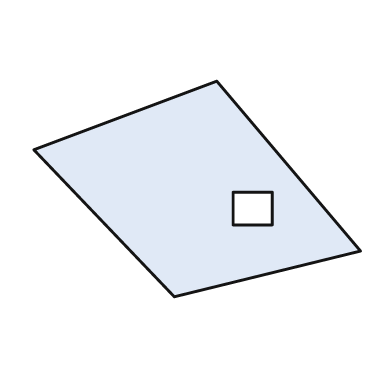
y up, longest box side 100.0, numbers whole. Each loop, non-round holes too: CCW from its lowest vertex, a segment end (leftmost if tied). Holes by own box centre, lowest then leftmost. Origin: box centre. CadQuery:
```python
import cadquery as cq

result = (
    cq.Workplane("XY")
    .moveTo(-7.0, -33.0)
    .lineTo(50.0, -19.0)
    .lineTo(6.0, 33.0)
    .lineTo(-50.0, 12.0)
    .close()
    .moveTo(11.0, -11.0)
    .lineTo(23.0, -11.0)
    .lineTo(23.0, -1.0)
    .lineTo(11.0, -1.0)
    .close()
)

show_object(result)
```